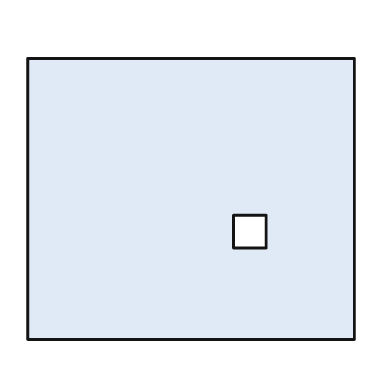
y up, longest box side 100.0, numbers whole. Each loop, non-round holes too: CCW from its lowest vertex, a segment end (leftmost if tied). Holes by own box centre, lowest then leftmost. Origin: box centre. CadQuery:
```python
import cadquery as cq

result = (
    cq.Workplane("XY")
    .moveTo(-50.0, -43.0)
    .lineTo(50.0, -43.0)
    .lineTo(50.0, 43.0)
    .lineTo(-50.0, 43.0)
    .close()
    .moveTo(13.0, -15.0)
    .lineTo(23.0, -15.0)
    .lineTo(23.0, -5.0)
    .lineTo(13.0, -5.0)
    .close()
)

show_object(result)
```